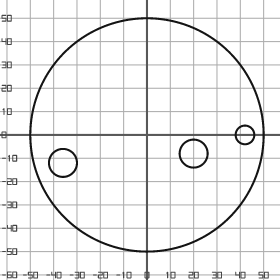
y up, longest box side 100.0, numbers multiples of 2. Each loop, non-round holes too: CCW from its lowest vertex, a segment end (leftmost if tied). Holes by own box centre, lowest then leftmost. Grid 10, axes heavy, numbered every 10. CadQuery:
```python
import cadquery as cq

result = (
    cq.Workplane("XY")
    .moveTo(0.0, 0.0)
    .circle(50.0)
    .moveTo(-36.0, -12.0)
    .circle(6.0)
    .moveTo(20.0, -8.0)
    .circle(6.0)
    .moveTo(42.0, 0.0)
    .circle(4.0)
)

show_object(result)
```